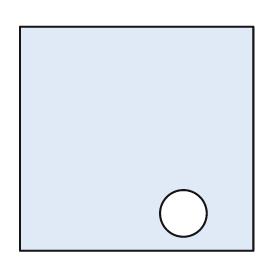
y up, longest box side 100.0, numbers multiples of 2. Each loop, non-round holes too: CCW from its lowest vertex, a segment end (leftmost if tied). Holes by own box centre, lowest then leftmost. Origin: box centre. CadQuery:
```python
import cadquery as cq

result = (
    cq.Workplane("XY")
    .moveTo(-50.0, -48.0)
    .lineTo(50.0, -48.0)
    .lineTo(50.0, 48.0)
    .lineTo(-50.0, 48.0)
    .close()
    .moveTo(20.0, -32.0)
    .circle(10.0)
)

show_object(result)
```